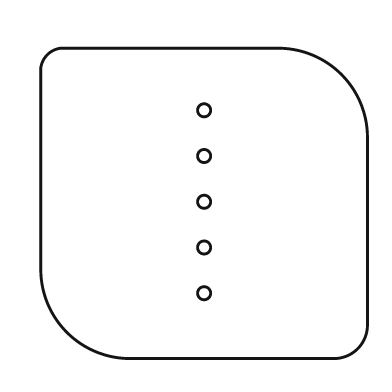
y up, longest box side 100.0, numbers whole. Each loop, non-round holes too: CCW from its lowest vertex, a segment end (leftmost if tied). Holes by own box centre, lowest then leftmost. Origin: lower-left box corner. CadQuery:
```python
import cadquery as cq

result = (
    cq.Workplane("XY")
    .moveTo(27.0, 0.0)
    .lineTo(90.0, 0.0)
    .threePointArc((97.0, 3.0), (100.0, 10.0))
    .lineTo(100.0, 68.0)
    .threePointArc((92.0, 87.0), (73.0, 95.0))
    .lineTo(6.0, 95.0)
    .threePointArc((2.0, 93.0), (0.0, 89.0))
    .lineTo(0.0, 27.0)
    .threePointArc((8.0, 8.0), (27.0, 0.0))
    .close()
    .moveTo(50.0, 20.0)
    .circle(2.0)
    .moveTo(50.0, 34.0)
    .circle(2.0)
    .moveTo(50.0, 48.0)
    .circle(2.0)
    .moveTo(50.0, 62.0)
    .circle(2.0)
    .moveTo(50.0, 76.0)
    .circle(2.0)
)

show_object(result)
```